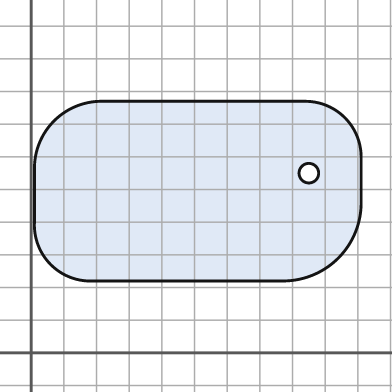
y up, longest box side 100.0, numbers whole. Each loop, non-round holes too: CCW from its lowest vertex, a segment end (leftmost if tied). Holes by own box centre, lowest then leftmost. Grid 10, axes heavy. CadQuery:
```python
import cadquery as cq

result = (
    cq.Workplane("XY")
    .moveTo(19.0, 22.0)
    .lineTo(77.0, 22.0)
    .threePointArc((94.0, 29.0), (101.0, 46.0))
    .lineTo(101.0, 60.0)
    .threePointArc((96.0, 72.0), (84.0, 77.0))
    .lineTo(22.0, 77.0)
    .threePointArc((7.0, 71.0), (1.0, 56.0))
    .lineTo(1.0, 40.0)
    .threePointArc((6.0, 27.0), (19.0, 22.0))
    .close()
    .moveTo(85.0, 55.0)
    .circle(3.0)
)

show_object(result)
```